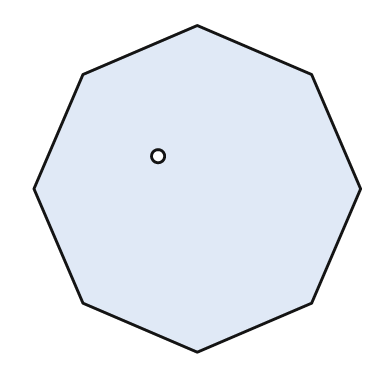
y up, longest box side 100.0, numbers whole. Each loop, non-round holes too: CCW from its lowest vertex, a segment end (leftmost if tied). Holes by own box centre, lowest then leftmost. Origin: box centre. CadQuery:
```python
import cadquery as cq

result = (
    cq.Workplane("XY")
    .moveTo(0.0, -50.0)
    .lineTo(35.0, -35.0)
    .lineTo(50.0, 0.0)
    .lineTo(35.0, 35.0)
    .lineTo(0.0, 50.0)
    .lineTo(-35.0, 35.0)
    .lineTo(-50.0, 0.0)
    .lineTo(-35.0, -35.0)
    .close()
    .moveTo(-12.0, 10.0)
    .circle(2.0)
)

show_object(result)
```